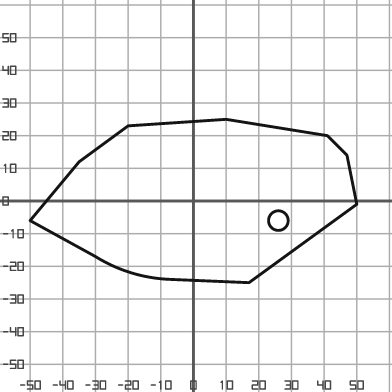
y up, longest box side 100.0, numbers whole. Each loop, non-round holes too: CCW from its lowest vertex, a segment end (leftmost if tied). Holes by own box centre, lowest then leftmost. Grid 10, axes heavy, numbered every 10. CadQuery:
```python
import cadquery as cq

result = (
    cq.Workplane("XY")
    .moveTo(17.0, -25.0)
    .lineTo(50.0, -1.0)
    .lineTo(47.0, 14.0)
    .lineTo(41.0, 20.0)
    .lineTo(10.0, 25.0)
    .lineTo(-20.0, 23.0)
    .lineTo(-35.0, 12.0)
    .lineTo(-50.0, -6.0)
    .lineTo(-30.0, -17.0)
    .threePointArc((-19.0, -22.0), (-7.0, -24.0))
    .close()
    .moveTo(26.0, -6.0)
    .circle(3.0)
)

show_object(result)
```